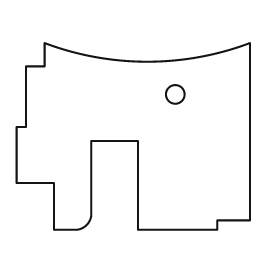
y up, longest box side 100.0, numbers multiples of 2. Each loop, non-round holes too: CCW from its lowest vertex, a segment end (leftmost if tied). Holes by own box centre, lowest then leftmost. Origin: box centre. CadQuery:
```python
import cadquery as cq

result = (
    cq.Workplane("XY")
    .moveTo(-34.0, -40.0)
    .lineTo(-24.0, -40.0)
    .threePointArc((-20.0, -38.0), (-18.0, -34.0))
    .lineTo(-18.0, -2.0)
    .lineTo(2.0, -2.0)
    .lineTo(2.0, -40.0)
    .lineTo(36.0, -40.0)
    .lineTo(36.0, -36.0)
    .lineTo(50.0, -36.0)
    .lineTo(50.0, 40.0)
    .threePointArc((6.0, 32.0), (-38.0, 40.0))
    .lineTo(-38.0, 30.0)
    .lineTo(-46.0, 30.0)
    .lineTo(-46.0, 4.0)
    .lineTo(-50.0, 4.0)
    .lineTo(-50.0, -20.0)
    .lineTo(-34.0, -20.0)
    .close()
    .moveTo(18.0, 18.0)
    .circle(4.0)
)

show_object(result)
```